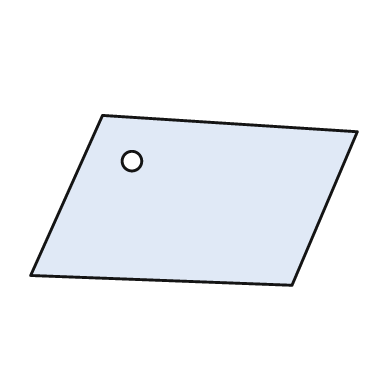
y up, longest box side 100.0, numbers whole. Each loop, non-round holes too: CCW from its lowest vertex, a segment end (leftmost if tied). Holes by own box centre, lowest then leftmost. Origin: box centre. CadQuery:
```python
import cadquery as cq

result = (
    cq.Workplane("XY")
    .moveTo(30.0, -26.0)
    .lineTo(50.0, 21.0)
    .lineTo(-28.0, 26.0)
    .lineTo(-50.0, -23.0)
    .close()
    .moveTo(-19.0, 12.0)
    .circle(3.0)
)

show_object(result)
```